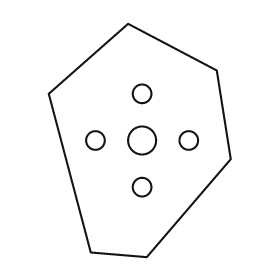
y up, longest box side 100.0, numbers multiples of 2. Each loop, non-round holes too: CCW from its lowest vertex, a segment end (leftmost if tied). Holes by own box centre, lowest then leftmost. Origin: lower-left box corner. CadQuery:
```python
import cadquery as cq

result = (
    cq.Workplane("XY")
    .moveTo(42.0, 0.0)
    .lineTo(78.0, 42.0)
    .lineTo(72.0, 80.0)
    .lineTo(34.0, 100.0)
    .lineTo(0.0, 70.0)
    .lineTo(18.0, 2.0)
    .close()
    .moveTo(40.0, 30.0)
    .circle(4.0)
    .moveTo(20.0, 50.0)
    .circle(4.0)
    .moveTo(40.0, 50.0)
    .circle(6.0)
    .moveTo(60.0, 50.0)
    .circle(4.0)
    .moveTo(40.0, 70.0)
    .circle(4.0)
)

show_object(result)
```